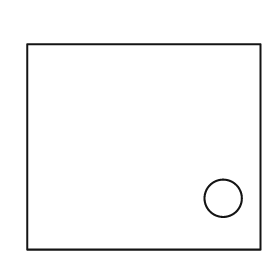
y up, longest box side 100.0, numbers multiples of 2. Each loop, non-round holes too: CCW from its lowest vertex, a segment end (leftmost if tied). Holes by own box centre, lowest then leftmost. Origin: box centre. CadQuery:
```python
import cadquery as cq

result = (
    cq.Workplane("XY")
    .moveTo(-50.0, -44.0)
    .lineTo(50.0, -44.0)
    .lineTo(50.0, 44.0)
    .lineTo(-50.0, 44.0)
    .close()
    .moveTo(34.0, -22.0)
    .circle(8.0)
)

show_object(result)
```